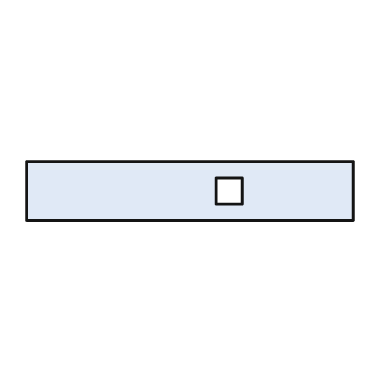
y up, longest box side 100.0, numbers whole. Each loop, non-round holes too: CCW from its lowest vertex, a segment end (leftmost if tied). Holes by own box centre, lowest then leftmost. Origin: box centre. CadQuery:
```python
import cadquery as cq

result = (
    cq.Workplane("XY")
    .moveTo(-50.0, -9.0)
    .lineTo(50.0, -9.0)
    .lineTo(50.0, 9.0)
    .lineTo(-50.0, 9.0)
    .close()
    .moveTo(8.0, -4.0)
    .lineTo(16.0, -4.0)
    .lineTo(16.0, 4.0)
    .lineTo(8.0, 4.0)
    .close()
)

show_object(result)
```